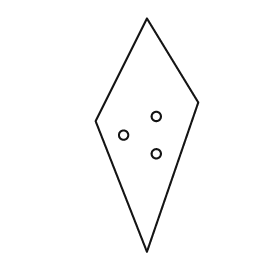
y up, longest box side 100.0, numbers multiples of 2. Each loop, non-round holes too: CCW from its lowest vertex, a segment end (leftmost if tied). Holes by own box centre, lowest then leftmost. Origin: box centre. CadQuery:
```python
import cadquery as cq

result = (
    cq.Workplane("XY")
    .moveTo(0.0, -50.0)
    .lineTo(22.0, 14.0)
    .lineTo(0.0, 50.0)
    .lineTo(-22.0, 6.0)
    .close()
    .moveTo(4.0, -8.0)
    .circle(2.0)
    .moveTo(-10.0, 0.0)
    .circle(2.0)
    .moveTo(4.0, 8.0)
    .circle(2.0)
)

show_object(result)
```